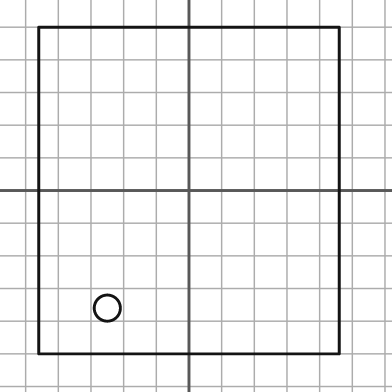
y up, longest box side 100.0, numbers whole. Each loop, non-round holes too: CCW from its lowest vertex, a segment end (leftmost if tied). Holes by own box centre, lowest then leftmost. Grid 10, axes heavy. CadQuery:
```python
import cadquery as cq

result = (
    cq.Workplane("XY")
    .moveTo(-46.0, -50.0)
    .lineTo(46.0, -50.0)
    .lineTo(46.0, 50.0)
    .lineTo(-46.0, 50.0)
    .close()
    .moveTo(-25.0, -36.0)
    .circle(4.0)
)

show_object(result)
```